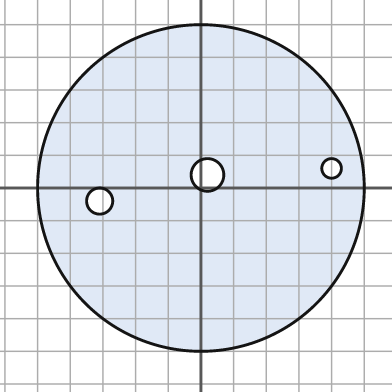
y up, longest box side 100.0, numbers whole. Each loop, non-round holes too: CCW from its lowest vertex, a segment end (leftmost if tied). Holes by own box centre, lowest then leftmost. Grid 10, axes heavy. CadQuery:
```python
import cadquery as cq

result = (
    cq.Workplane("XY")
    .moveTo(0.0, 0.0)
    .circle(50.0)
    .moveTo(-31.0, -4.0)
    .circle(4.0)
    .moveTo(2.0, 4.0)
    .circle(5.0)
    .moveTo(40.0, 6.0)
    .circle(3.0)
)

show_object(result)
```